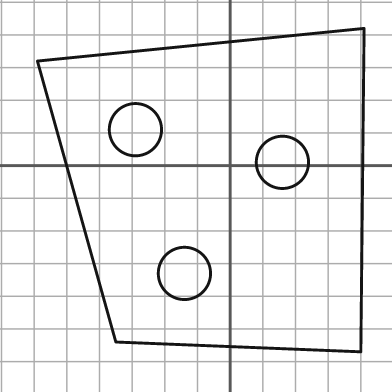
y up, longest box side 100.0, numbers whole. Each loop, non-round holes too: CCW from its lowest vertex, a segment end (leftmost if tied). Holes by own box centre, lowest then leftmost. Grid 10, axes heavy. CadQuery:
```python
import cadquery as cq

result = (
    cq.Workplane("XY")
    .moveTo(40.0, -57.0)
    .lineTo(41.0, 42.0)
    .lineTo(-59.0, 32.0)
    .lineTo(-35.0, -54.0)
    .close()
    .moveTo(-14.0, -33.0)
    .circle(8.0)
    .moveTo(16.0, 1.0)
    .circle(8.0)
    .moveTo(-29.0, 11.0)
    .circle(8.0)
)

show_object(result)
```